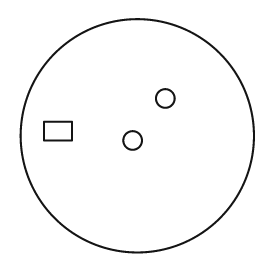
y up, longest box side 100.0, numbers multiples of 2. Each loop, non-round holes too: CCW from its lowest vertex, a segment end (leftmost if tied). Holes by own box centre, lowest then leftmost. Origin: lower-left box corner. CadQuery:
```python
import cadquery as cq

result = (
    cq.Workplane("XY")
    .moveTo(50.0, 50.0)
    .circle(50.0)
    .moveTo(48.0, 48.0)
    .circle(4.0)
    .moveTo(10.0, 48.0)
    .lineTo(22.0, 48.0)
    .lineTo(22.0, 56.0)
    .lineTo(10.0, 56.0)
    .close()
    .moveTo(62.0, 66.0)
    .circle(4.0)
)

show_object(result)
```